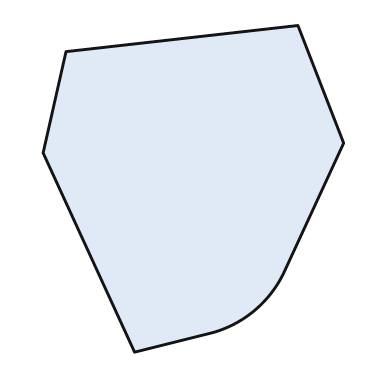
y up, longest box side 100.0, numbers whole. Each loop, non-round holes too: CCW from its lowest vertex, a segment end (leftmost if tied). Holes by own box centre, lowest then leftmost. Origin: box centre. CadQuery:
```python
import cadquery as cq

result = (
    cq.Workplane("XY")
    .moveTo(-18.0, -50.0)
    .lineTo(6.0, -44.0)
    .threePointArc((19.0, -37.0), (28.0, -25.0))
    .lineTo(46.0, 14.0)
    .lineTo(32.0, 50.0)
    .lineTo(-39.0, 42.0)
    .lineTo(-46.0, 11.0)
    .close()
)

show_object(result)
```